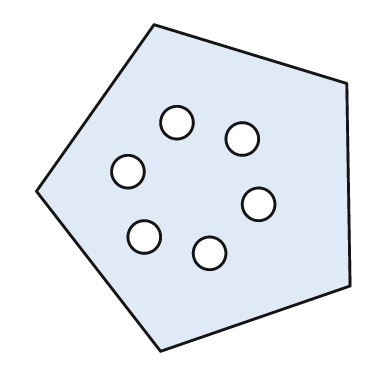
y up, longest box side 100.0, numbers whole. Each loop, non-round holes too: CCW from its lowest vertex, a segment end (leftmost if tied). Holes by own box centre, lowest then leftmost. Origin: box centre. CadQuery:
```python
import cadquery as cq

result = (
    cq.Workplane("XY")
    .moveTo(-10.0, -50.0)
    .lineTo(48.0, -30.0)
    .lineTo(47.0, 32.0)
    .lineTo(-12.0, 50.0)
    .lineTo(-48.0, -1.0)
    .close()
    .moveTo(5.0, -20.0)
    .circle(5.0)
    .moveTo(-15.0, -15.0)
    .circle(5.0)
    .moveTo(20.0, -5.0)
    .circle(5.0)
    .moveTo(-20.0, 5.0)
    .circle(5.0)
    .moveTo(15.0, 15.0)
    .circle(5.0)
    .moveTo(-5.0, 20.0)
    .circle(5.0)
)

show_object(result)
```